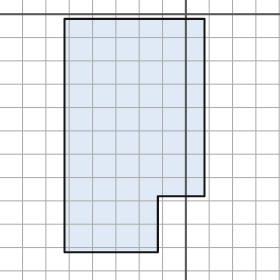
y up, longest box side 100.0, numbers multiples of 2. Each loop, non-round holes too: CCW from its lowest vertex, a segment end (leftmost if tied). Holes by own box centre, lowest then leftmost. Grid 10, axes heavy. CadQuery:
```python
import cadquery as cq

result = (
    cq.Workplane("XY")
    .moveTo(-52.0, -102.0)
    .lineTo(-12.0, -102.0)
    .lineTo(-12.0, -78.0)
    .lineTo(8.0, -78.0)
    .lineTo(8.0, -2.0)
    .lineTo(-52.0, -2.0)
    .close()
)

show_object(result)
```